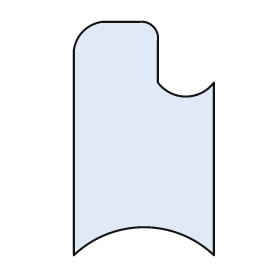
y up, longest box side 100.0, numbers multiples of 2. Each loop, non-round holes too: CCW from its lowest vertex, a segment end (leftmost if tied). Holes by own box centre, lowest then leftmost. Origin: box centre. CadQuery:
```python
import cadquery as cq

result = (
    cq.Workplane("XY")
    .moveTo(-30.0, -50.0)
    .threePointArc((0.0, -38.0), (30.0, -50.0))
    .lineTo(30.0, 24.0)
    .threePointArc((18.0, 18.0), (6.0, 24.0))
    .lineTo(6.0, 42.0)
    .threePointArc((4.0, 48.0), (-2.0, 50.0))
    .lineTo(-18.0, 50.0)
    .threePointArc((-26.0, 46.0), (-30.0, 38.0))
    .close()
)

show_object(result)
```